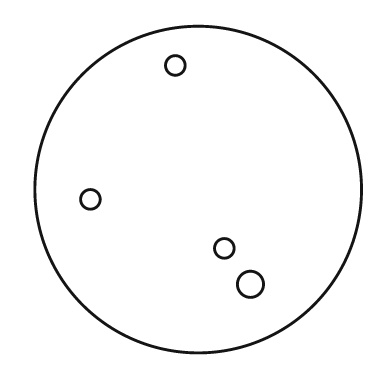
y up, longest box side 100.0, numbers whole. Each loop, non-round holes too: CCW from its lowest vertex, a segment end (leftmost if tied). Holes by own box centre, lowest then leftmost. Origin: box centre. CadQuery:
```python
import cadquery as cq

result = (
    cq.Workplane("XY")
    .moveTo(0.0, 0.0)
    .circle(50.0)
    .moveTo(16.0, -29.0)
    .circle(4.0)
    .moveTo(8.0, -18.0)
    .circle(3.0)
    .moveTo(-33.0, -3.0)
    .circle(3.0)
    .moveTo(-7.0, 38.0)
    .circle(3.0)
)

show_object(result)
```